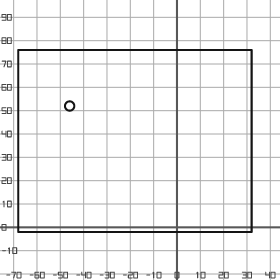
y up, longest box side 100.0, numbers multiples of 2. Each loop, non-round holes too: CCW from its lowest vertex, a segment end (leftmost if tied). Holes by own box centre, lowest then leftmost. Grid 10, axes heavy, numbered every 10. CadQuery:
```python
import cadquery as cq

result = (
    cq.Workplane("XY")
    .moveTo(-68.0, -2.0)
    .lineTo(32.0, -2.0)
    .lineTo(32.0, 76.0)
    .lineTo(-68.0, 76.0)
    .close()
    .moveTo(-46.0, 52.0)
    .circle(2.0)
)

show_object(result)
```